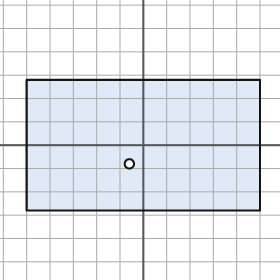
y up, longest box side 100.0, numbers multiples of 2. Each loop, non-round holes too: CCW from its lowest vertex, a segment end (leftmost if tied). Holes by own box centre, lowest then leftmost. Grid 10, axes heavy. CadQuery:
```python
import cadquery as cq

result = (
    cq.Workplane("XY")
    .moveTo(-50.0, -28.0)
    .lineTo(50.0, -28.0)
    .lineTo(50.0, 28.0)
    .lineTo(-50.0, 28.0)
    .close()
    .moveTo(-6.0, -8.0)
    .circle(2.0)
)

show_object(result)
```